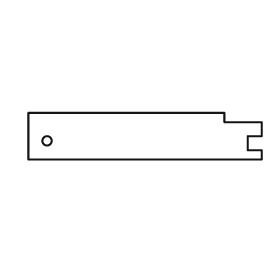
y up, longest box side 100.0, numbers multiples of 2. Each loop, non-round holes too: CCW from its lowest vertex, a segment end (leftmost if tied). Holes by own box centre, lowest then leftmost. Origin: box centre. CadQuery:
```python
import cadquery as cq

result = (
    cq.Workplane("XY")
    .moveTo(-50.0, -10.0)
    .lineTo(50.0, -10.0)
    .lineTo(50.0, -6.0)
    .lineTo(44.0, -6.0)
    .lineTo(44.0, 0.0)
    .lineTo(50.0, 0.0)
    .lineTo(50.0, 6.0)
    .lineTo(34.0, 6.0)
    .lineTo(34.0, 10.0)
    .lineTo(-50.0, 10.0)
    .close()
    .moveTo(-42.0, -2.0)
    .circle(2.0)
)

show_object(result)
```